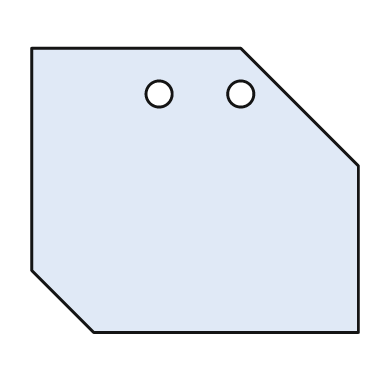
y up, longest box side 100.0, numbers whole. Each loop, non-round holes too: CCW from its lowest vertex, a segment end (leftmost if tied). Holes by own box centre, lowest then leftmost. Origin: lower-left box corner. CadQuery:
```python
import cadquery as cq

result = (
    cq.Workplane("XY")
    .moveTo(19.0, 0.0)
    .lineTo(100.0, 0.0)
    .lineTo(100.0, 51.0)
    .lineTo(64.0, 87.0)
    .lineTo(0.0, 87.0)
    .lineTo(0.0, 19.0)
    .close()
    .moveTo(39.0, 73.0)
    .circle(4.0)
    .moveTo(64.0, 73.0)
    .circle(4.0)
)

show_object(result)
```